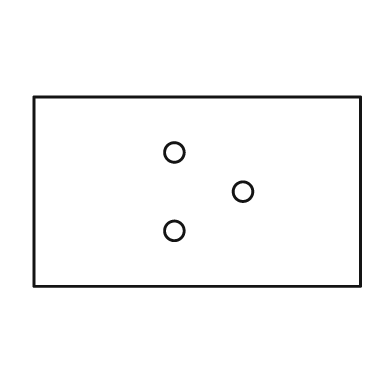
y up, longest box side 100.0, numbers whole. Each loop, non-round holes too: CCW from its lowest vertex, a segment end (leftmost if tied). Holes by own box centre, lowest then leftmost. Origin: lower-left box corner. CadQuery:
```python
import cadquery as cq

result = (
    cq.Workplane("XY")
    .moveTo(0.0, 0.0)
    .lineTo(100.0, 0.0)
    .lineTo(100.0, 58.0)
    .lineTo(0.0, 58.0)
    .close()
    .moveTo(43.0, 17.0)
    .circle(3.0)
    .moveTo(64.0, 29.0)
    .circle(3.0)
    .moveTo(43.0, 41.0)
    .circle(3.0)
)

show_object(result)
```